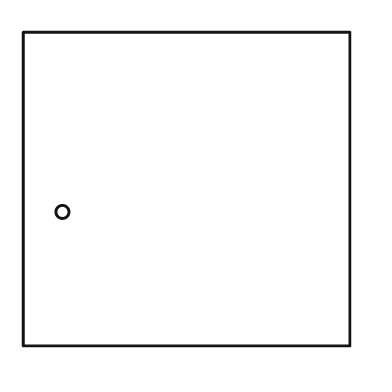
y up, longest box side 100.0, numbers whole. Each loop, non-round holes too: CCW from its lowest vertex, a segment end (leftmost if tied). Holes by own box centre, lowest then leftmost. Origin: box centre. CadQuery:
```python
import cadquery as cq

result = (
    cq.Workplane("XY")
    .moveTo(-50.0, -48.0)
    .lineTo(50.0, -48.0)
    .lineTo(50.0, 48.0)
    .lineTo(-50.0, 48.0)
    .close()
    .moveTo(-38.0, -7.0)
    .circle(2.0)
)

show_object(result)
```